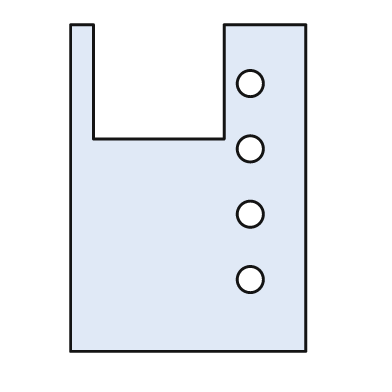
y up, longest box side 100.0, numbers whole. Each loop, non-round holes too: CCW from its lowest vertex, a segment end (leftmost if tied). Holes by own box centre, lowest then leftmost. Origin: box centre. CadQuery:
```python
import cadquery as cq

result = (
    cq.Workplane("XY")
    .moveTo(-36.0, -50.0)
    .lineTo(36.0, -50.0)
    .lineTo(36.0, 50.0)
    .lineTo(11.0, 50.0)
    .lineTo(11.0, 15.0)
    .lineTo(-29.0, 15.0)
    .lineTo(-29.0, 50.0)
    .lineTo(-36.0, 50.0)
    .close()
    .moveTo(19.0, -28.0)
    .circle(4.0)
    .moveTo(19.0, -8.0)
    .circle(4.0)
    .moveTo(19.0, 12.0)
    .circle(4.0)
    .moveTo(19.0, 32.0)
    .circle(4.0)
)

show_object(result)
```